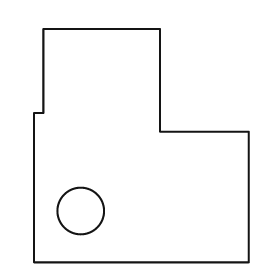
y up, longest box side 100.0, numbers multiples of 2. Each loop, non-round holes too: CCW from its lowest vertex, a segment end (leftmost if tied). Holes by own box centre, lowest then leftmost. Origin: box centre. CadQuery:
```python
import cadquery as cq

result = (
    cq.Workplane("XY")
    .moveTo(-46.0, -50.0)
    .lineTo(46.0, -50.0)
    .lineTo(46.0, 6.0)
    .lineTo(8.0, 6.0)
    .lineTo(8.0, 50.0)
    .lineTo(-42.0, 50.0)
    .lineTo(-42.0, 14.0)
    .lineTo(-46.0, 14.0)
    .close()
    .moveTo(-26.0, -28.0)
    .circle(10.0)
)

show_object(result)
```